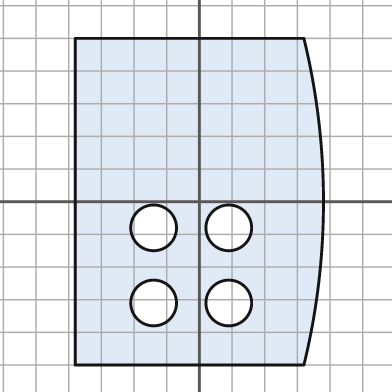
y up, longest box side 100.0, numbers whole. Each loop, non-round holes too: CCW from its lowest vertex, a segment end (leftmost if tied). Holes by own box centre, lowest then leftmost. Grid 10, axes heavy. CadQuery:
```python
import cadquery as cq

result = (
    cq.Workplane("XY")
    .moveTo(-38.0, -50.0)
    .lineTo(32.0, -50.0)
    .threePointArc((38.0, 0.0), (32.0, 50.0))
    .lineTo(-38.0, 50.0)
    .close()
    .moveTo(-14.0, -31.0)
    .circle(7.0)
    .moveTo(9.0, -31.0)
    .circle(7.0)
    .moveTo(-14.0, -8.0)
    .circle(7.0)
    .moveTo(9.0, -8.0)
    .circle(7.0)
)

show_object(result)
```